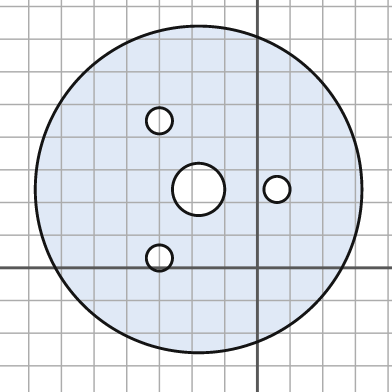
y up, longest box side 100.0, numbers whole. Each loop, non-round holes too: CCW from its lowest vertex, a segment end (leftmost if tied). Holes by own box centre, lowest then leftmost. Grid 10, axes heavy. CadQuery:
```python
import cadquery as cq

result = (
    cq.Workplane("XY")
    .moveTo(-18.0, 24.0)
    .circle(50.0)
    .moveTo(-30.0, 3.0)
    .circle(4.0)
    .moveTo(-18.0, 24.0)
    .circle(8.0)
    .moveTo(6.0, 24.0)
    .circle(4.0)
    .moveTo(-30.0, 45.0)
    .circle(4.0)
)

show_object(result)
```